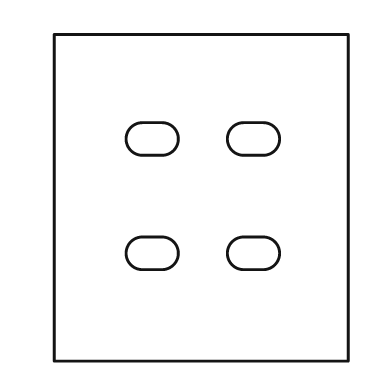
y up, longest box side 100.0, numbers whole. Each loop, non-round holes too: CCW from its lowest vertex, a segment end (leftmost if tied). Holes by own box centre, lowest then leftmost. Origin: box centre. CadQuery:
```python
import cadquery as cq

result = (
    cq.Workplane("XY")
    .moveTo(-45.0, -50.0)
    .lineTo(45.0, -50.0)
    .lineTo(45.0, 50.0)
    .lineTo(-45.0, 50.0)
    .close()
    .moveTo(-18.0, -22.0)
    .lineTo(-12.0, -22.0)
    .threePointArc((-7.0, -17.0), (-12.0, -12.0))
    .lineTo(-18.0, -12.0)
    .threePointArc((-23.0, -17.0), (-18.0, -22.0))
    .close()
    .moveTo(13.0, -22.0)
    .lineTo(19.0, -22.0)
    .threePointArc((24.0, -17.0), (19.0, -12.0))
    .lineTo(13.0, -12.0)
    .threePointArc((8.0, -17.0), (13.0, -22.0))
    .close()
    .moveTo(-18.0, 13.0)
    .lineTo(-12.0, 13.0)
    .threePointArc((-7.0, 18.0), (-12.0, 23.0))
    .lineTo(-18.0, 23.0)
    .threePointArc((-23.0, 18.0), (-18.0, 13.0))
    .close()
    .moveTo(13.0, 13.0)
    .lineTo(19.0, 13.0)
    .threePointArc((24.0, 18.0), (19.0, 23.0))
    .lineTo(13.0, 23.0)
    .threePointArc((8.0, 18.0), (13.0, 13.0))
    .close()
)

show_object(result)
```